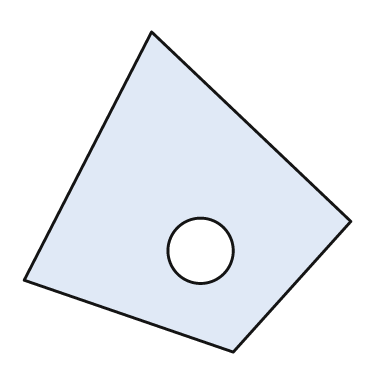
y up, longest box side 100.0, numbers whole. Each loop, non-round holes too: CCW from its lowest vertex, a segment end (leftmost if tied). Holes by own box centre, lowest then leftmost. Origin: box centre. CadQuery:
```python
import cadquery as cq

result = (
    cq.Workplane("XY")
    .moveTo(14.0, -49.0)
    .lineTo(50.0, -9.0)
    .lineTo(-11.0, 49.0)
    .lineTo(-50.0, -27.0)
    .close()
    .moveTo(4.0, -18.0)
    .circle(10.0)
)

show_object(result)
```